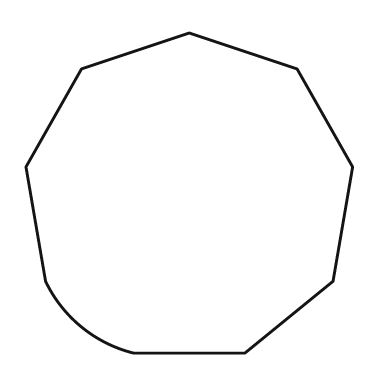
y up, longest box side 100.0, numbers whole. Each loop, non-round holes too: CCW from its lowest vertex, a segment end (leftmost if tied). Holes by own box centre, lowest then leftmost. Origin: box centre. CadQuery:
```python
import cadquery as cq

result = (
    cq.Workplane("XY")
    .moveTo(-17.0, -49.0)
    .lineTo(17.0, -49.0)
    .lineTo(44.0, -27.0)
    .lineTo(50.0, 8.0)
    .lineTo(33.0, 38.0)
    .lineTo(0.0, 49.0)
    .lineTo(-33.0, 38.0)
    .lineTo(-50.0, 8.0)
    .lineTo(-44.0, -27.0)
    .threePointArc((-33.0, -41.0), (-17.0, -49.0))
    .close()
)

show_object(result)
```